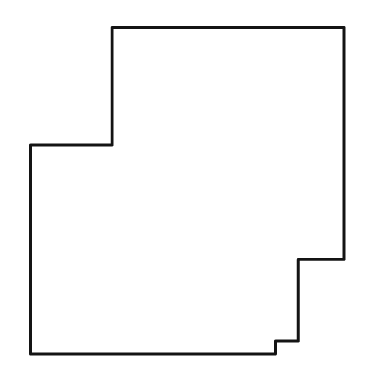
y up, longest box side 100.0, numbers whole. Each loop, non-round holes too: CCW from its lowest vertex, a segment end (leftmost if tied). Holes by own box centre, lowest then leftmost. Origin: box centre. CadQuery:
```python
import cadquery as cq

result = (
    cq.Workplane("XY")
    .moveTo(-48.0, -50.0)
    .lineTo(27.0, -50.0)
    .lineTo(27.0, -46.0)
    .lineTo(34.0, -46.0)
    .lineTo(34.0, -21.0)
    .lineTo(48.0, -21.0)
    .lineTo(48.0, 50.0)
    .lineTo(-23.0, 50.0)
    .lineTo(-23.0, 14.0)
    .lineTo(-48.0, 14.0)
    .close()
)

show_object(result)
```